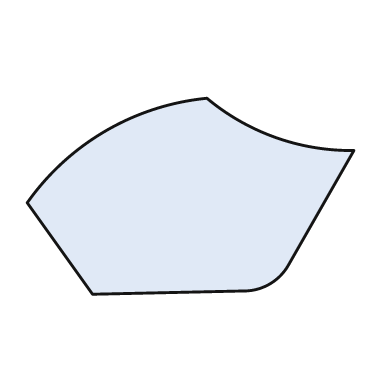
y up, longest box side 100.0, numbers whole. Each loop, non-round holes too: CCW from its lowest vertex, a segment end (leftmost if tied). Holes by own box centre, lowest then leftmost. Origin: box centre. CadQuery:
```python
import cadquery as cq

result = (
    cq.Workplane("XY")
    .moveTo(-30.0, -30.0)
    .lineTo(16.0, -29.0)
    .threePointArc((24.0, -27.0), (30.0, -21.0))
    .lineTo(50.0, 14.0)
    .threePointArc((26.0, 18.0), (5.0, 30.0))
    .threePointArc((-26.0, 20.0), (-50.0, -2.0))
    .close()
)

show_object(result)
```